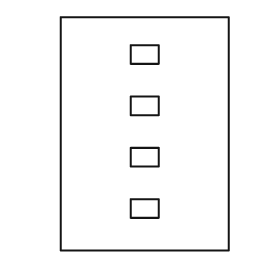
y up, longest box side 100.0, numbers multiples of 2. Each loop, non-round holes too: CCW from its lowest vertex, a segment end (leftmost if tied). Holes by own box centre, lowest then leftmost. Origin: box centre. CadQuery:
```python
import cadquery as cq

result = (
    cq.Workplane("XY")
    .moveTo(-36.0, -50.0)
    .lineTo(36.0, -50.0)
    .lineTo(36.0, 50.0)
    .lineTo(-36.0, 50.0)
    .close()
    .moveTo(-6.0, -36.0)
    .lineTo(6.0, -36.0)
    .lineTo(6.0, -28.0)
    .lineTo(-6.0, -28.0)
    .close()
    .moveTo(-6.0, -14.0)
    .lineTo(6.0, -14.0)
    .lineTo(6.0, -6.0)
    .lineTo(-6.0, -6.0)
    .close()
    .moveTo(-6.0, 8.0)
    .lineTo(6.0, 8.0)
    .lineTo(6.0, 16.0)
    .lineTo(-6.0, 16.0)
    .close()
    .moveTo(-6.0, 30.0)
    .lineTo(6.0, 30.0)
    .lineTo(6.0, 38.0)
    .lineTo(-6.0, 38.0)
    .close()
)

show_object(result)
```